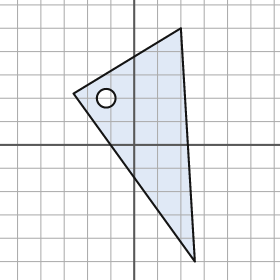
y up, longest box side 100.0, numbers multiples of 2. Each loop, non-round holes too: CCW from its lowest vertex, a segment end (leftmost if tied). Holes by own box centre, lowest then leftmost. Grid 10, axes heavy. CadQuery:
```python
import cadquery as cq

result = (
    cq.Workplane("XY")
    .moveTo(26.0, -50.0)
    .lineTo(20.0, 50.0)
    .lineTo(-26.0, 22.0)
    .close()
    .moveTo(-12.0, 20.0)
    .circle(4.0)
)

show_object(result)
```